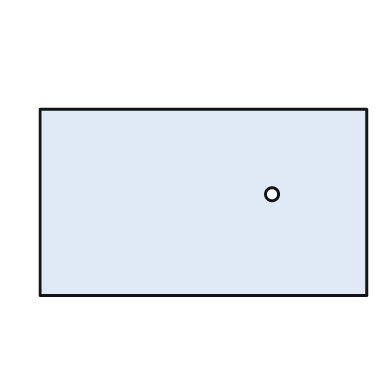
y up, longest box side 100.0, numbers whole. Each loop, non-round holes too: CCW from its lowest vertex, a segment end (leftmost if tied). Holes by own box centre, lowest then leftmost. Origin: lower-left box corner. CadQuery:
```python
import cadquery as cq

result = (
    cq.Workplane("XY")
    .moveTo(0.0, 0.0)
    .lineTo(100.0, 0.0)
    .lineTo(100.0, 57.0)
    .lineTo(0.0, 57.0)
    .close()
    .moveTo(71.0, 31.0)
    .circle(2.0)
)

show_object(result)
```